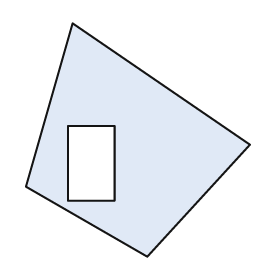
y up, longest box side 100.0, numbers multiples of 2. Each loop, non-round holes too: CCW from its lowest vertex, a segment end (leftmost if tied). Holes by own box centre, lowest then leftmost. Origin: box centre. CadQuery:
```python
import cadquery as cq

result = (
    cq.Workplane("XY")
    .moveTo(4.0, -50.0)
    .lineTo(48.0, -2.0)
    .lineTo(-28.0, 50.0)
    .lineTo(-48.0, -20.0)
    .close()
    .moveTo(-30.0, -26.0)
    .lineTo(-10.0, -26.0)
    .lineTo(-10.0, 6.0)
    .lineTo(-30.0, 6.0)
    .close()
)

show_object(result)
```